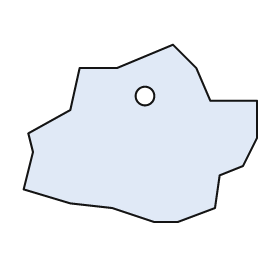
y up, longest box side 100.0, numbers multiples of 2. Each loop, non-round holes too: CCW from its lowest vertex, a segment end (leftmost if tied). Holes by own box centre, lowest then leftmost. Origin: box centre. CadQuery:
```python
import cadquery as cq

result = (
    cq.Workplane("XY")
    .moveTo(6.0, -38.0)
    .lineTo(16.0, -38.0)
    .lineTo(32.0, -32.0)
    .lineTo(34.0, -18.0)
    .lineTo(44.0, -14.0)
    .lineTo(50.0, -2.0)
    .lineTo(50.0, 14.0)
    .lineTo(30.0, 14.0)
    .lineTo(24.0, 28.0)
    .lineTo(14.0, 38.0)
    .lineTo(-10.0, 28.0)
    .lineTo(-26.0, 28.0)
    .lineTo(-30.0, 10.0)
    .lineTo(-48.0, 0.0)
    .lineTo(-46.0, -8.0)
    .lineTo(-50.0, -24.0)
    .lineTo(-30.0, -30.0)
    .lineTo(-12.0, -32.0)
    .close()
    .moveTo(2.0, 16.0)
    .circle(4.0)
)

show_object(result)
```